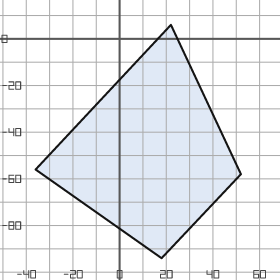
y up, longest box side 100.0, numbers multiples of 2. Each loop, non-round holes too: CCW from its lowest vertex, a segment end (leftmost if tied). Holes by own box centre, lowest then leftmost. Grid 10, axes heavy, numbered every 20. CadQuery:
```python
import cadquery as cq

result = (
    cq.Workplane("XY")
    .moveTo(18.0, -94.0)
    .lineTo(52.0, -58.0)
    .lineTo(22.0, 6.0)
    .lineTo(-36.0, -56.0)
    .close()
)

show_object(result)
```